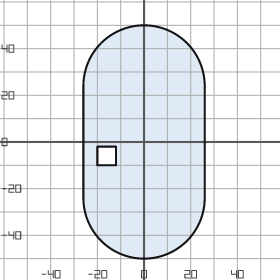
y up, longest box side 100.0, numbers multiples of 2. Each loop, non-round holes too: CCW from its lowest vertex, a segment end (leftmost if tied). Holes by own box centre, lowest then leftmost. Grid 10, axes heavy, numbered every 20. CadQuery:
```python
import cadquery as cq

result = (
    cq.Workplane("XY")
    .moveTo(-26.0, -24.0)
    .threePointArc((0.0, -50.0), (26.0, -24.0))
    .lineTo(26.0, 24.0)
    .threePointArc((0.0, 50.0), (-26.0, 24.0))
    .close()
    .moveTo(-20.0, -10.0)
    .lineTo(-12.0, -10.0)
    .lineTo(-12.0, -2.0)
    .lineTo(-20.0, -2.0)
    .close()
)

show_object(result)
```